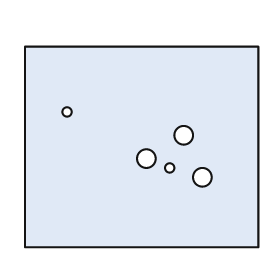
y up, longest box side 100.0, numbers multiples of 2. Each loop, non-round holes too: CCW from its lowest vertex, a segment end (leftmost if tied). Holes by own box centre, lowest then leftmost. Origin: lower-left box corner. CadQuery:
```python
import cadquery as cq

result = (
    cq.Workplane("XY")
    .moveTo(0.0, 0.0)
    .lineTo(100.0, 0.0)
    .lineTo(100.0, 86.0)
    .lineTo(0.0, 86.0)
    .close()
    .moveTo(76.0, 30.0)
    .circle(4.0)
    .moveTo(62.0, 34.0)
    .circle(2.0)
    .moveTo(52.0, 38.0)
    .circle(4.0)
    .moveTo(68.0, 48.0)
    .circle(4.0)
    .moveTo(18.0, 58.0)
    .circle(2.0)
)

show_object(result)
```